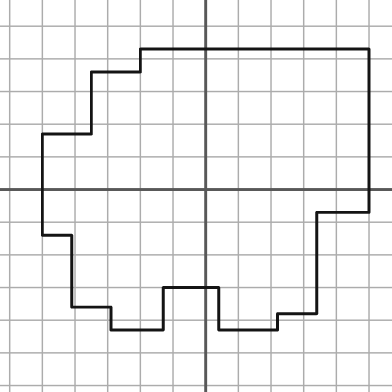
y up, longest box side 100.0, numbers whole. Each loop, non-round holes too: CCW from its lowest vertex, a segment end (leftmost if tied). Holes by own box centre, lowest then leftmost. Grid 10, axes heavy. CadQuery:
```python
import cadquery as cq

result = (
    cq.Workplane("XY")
    .moveTo(-29.0, -43.0)
    .lineTo(-13.0, -43.0)
    .lineTo(-13.0, -30.0)
    .lineTo(4.0, -30.0)
    .lineTo(4.0, -43.0)
    .lineTo(22.0, -43.0)
    .lineTo(22.0, -38.0)
    .lineTo(34.0, -38.0)
    .lineTo(34.0, -7.0)
    .lineTo(50.0, -7.0)
    .lineTo(50.0, 43.0)
    .lineTo(-20.0, 43.0)
    .lineTo(-20.0, 36.0)
    .lineTo(-35.0, 36.0)
    .lineTo(-35.0, 17.0)
    .lineTo(-50.0, 17.0)
    .lineTo(-50.0, -14.0)
    .lineTo(-41.0, -14.0)
    .lineTo(-41.0, -36.0)
    .lineTo(-29.0, -36.0)
    .close()
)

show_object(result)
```